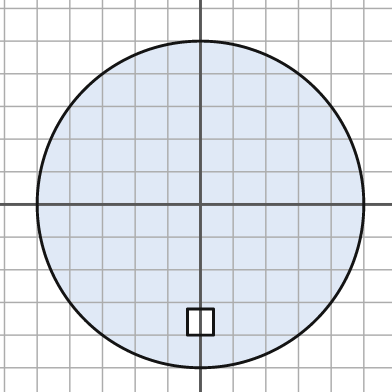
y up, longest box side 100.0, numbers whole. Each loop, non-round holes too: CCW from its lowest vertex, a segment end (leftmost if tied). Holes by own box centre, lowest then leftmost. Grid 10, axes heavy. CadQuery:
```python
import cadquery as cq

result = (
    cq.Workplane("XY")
    .moveTo(0.0, 0.0)
    .circle(50.0)
    .moveTo(-4.0, -40.0)
    .lineTo(4.0, -40.0)
    .lineTo(4.0, -32.0)
    .lineTo(-4.0, -32.0)
    .close()
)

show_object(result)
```